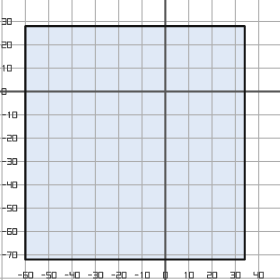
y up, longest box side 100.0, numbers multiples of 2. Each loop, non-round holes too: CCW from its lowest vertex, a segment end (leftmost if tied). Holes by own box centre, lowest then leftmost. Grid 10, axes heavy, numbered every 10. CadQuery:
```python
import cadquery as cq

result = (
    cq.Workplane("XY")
    .moveTo(-60.0, -72.0)
    .lineTo(34.0, -72.0)
    .lineTo(34.0, 28.0)
    .lineTo(-60.0, 28.0)
    .close()
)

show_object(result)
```